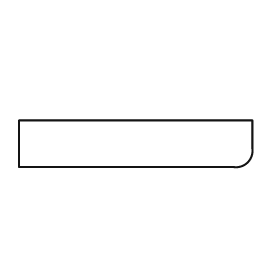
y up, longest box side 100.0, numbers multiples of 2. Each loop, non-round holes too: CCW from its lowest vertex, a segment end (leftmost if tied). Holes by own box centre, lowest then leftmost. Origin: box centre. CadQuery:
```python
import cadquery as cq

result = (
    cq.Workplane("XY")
    .moveTo(-50.0, -10.0)
    .lineTo(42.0, -10.0)
    .threePointArc((48.0, -8.0), (50.0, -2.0))
    .lineTo(50.0, 10.0)
    .lineTo(-50.0, 10.0)
    .close()
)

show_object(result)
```